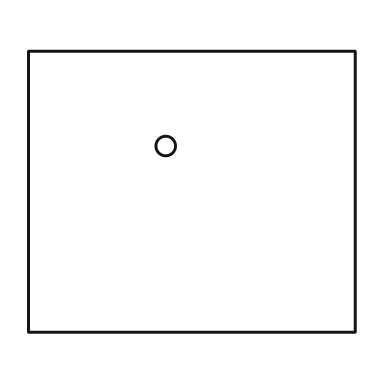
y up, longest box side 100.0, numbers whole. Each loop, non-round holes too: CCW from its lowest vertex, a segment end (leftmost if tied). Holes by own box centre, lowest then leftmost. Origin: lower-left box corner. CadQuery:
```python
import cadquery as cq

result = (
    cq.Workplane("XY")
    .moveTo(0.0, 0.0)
    .lineTo(100.0, 0.0)
    .lineTo(100.0, 86.0)
    .lineTo(0.0, 86.0)
    .close()
    .moveTo(42.0, 57.0)
    .circle(3.0)
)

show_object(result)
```